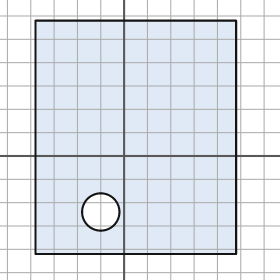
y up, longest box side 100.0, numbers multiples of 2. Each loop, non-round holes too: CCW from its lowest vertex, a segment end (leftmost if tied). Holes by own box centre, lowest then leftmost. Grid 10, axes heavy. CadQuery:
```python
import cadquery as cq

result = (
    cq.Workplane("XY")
    .moveTo(-38.0, -42.0)
    .lineTo(48.0, -42.0)
    .lineTo(48.0, 58.0)
    .lineTo(-38.0, 58.0)
    .close()
    .moveTo(-10.0, -24.0)
    .circle(8.0)
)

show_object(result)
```